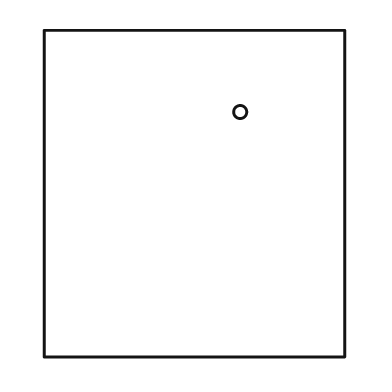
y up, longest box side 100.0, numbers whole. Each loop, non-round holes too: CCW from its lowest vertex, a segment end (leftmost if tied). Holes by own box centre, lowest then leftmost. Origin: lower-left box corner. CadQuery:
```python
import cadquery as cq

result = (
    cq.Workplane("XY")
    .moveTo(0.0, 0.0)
    .lineTo(92.0, 0.0)
    .lineTo(92.0, 100.0)
    .lineTo(0.0, 100.0)
    .close()
    .moveTo(60.0, 75.0)
    .circle(2.0)
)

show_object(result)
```